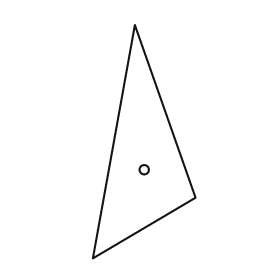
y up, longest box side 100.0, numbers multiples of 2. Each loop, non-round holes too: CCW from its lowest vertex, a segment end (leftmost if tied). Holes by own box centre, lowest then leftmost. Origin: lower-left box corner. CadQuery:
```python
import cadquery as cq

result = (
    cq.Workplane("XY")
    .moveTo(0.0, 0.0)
    .lineTo(44.0, 26.0)
    .lineTo(18.0, 100.0)
    .close()
    .moveTo(22.0, 38.0)
    .circle(2.0)
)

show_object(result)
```